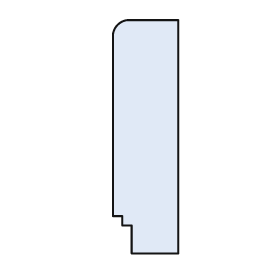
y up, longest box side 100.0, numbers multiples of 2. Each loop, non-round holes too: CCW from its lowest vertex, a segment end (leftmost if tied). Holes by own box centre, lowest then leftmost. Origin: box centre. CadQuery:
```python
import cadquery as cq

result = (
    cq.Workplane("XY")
    .moveTo(-6.0, -50.0)
    .lineTo(14.0, -50.0)
    .lineTo(14.0, 50.0)
    .lineTo(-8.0, 50.0)
    .threePointArc((-12.0, 48.0), (-14.0, 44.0))
    .lineTo(-14.0, -34.0)
    .lineTo(-10.0, -34.0)
    .lineTo(-10.0, -38.0)
    .lineTo(-6.0, -38.0)
    .close()
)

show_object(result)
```